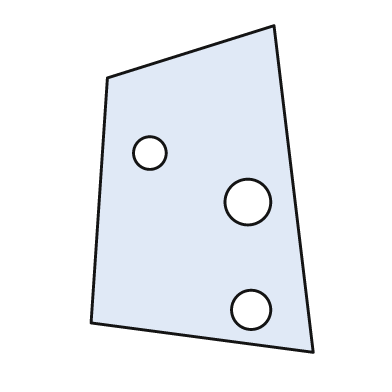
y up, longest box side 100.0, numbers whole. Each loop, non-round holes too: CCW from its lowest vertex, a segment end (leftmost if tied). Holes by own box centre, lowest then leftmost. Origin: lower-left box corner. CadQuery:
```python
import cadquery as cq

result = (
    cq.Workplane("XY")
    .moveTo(68.0, 0.0)
    .lineTo(56.0, 100.0)
    .lineTo(5.0, 84.0)
    .lineTo(0.0, 9.0)
    .close()
    .moveTo(49.0, 13.0)
    .circle(6.0)
    .moveTo(48.0, 46.0)
    .circle(7.0)
    .moveTo(18.0, 61.0)
    .circle(5.0)
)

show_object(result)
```